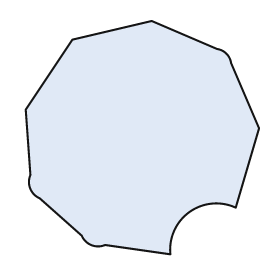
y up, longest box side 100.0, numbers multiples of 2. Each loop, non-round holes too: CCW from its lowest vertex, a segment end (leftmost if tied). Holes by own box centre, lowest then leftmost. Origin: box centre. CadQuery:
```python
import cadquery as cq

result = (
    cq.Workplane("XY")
    .moveTo(12.0, -50.0)
    .threePointArc((20.0, -32.0), (40.0, -30.0))
    .lineTo(50.0, 4.0)
    .lineTo(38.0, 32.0)
    .threePointArc((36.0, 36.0), (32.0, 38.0))
    .lineTo(4.0, 50.0)
    .lineTo(-30.0, 42.0)
    .lineTo(-50.0, 12.0)
    .lineTo(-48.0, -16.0)
    .threePointArc((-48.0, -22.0), (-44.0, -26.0))
    .lineTo(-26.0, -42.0)
    .threePointArc((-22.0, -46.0), (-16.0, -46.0))
    .close()
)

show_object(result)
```